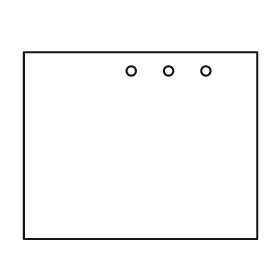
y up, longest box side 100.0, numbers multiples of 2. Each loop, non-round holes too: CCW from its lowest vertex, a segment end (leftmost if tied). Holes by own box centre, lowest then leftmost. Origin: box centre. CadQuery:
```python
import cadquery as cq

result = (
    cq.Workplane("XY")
    .moveTo(-50.0, -40.0)
    .lineTo(50.0, -40.0)
    .lineTo(50.0, 40.0)
    .lineTo(-50.0, 40.0)
    .close()
    .moveTo(-4.0, 32.0)
    .circle(2.0)
    .moveTo(12.0, 32.0)
    .circle(2.0)
    .moveTo(28.0, 32.0)
    .circle(2.0)
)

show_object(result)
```